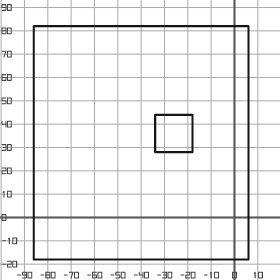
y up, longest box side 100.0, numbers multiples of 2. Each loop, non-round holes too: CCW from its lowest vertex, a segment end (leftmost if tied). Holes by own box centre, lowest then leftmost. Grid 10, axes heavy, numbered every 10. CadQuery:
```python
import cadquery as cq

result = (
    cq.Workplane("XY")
    .moveTo(-86.0, -18.0)
    .lineTo(6.0, -18.0)
    .lineTo(6.0, 82.0)
    .lineTo(-86.0, 82.0)
    .close()
    .moveTo(-34.0, 28.0)
    .lineTo(-18.0, 28.0)
    .lineTo(-18.0, 44.0)
    .lineTo(-34.0, 44.0)
    .close()
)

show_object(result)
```